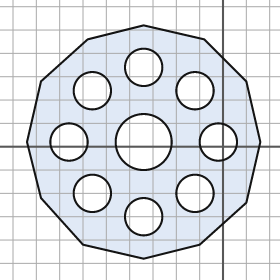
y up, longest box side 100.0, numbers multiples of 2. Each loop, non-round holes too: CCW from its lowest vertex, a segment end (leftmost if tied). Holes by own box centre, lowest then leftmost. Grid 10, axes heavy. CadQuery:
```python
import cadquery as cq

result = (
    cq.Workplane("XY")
    .moveTo(-34.0, -48.0)
    .lineTo(-10.0, -42.0)
    .lineTo(10.0, -24.0)
    .lineTo(16.0, 2.0)
    .lineTo(10.0, 28.0)
    .lineTo(-8.0, 46.0)
    .lineTo(-34.0, 52.0)
    .lineTo(-58.0, 46.0)
    .lineTo(-78.0, 28.0)
    .lineTo(-84.0, 2.0)
    .lineTo(-78.0, -22.0)
    .lineTo(-60.0, -42.0)
    .close()
    .moveTo(-34.0, -30.0)
    .circle(8.0)
    .moveTo(-56.0, -20.0)
    .circle(8.0)
    .moveTo(-12.0, -20.0)
    .circle(8.0)
    .moveTo(-66.0, 2.0)
    .circle(8.0)
    .moveTo(-34.0, 2.0)
    .circle(12.0)
    .moveTo(-2.0, 2.0)
    .circle(8.0)
    .moveTo(-56.0, 24.0)
    .circle(8.0)
    .moveTo(-12.0, 24.0)
    .circle(8.0)
    .moveTo(-34.0, 34.0)
    .circle(8.0)
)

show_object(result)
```